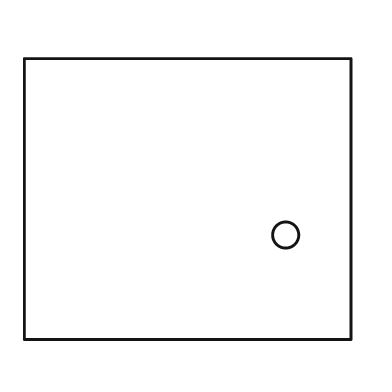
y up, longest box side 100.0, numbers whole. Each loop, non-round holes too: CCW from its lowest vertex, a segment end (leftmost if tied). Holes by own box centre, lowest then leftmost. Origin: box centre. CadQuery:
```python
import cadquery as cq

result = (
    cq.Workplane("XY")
    .moveTo(-50.0, -43.0)
    .lineTo(50.0, -43.0)
    .lineTo(50.0, 43.0)
    .lineTo(-50.0, 43.0)
    .close()
    .moveTo(30.0, -11.0)
    .circle(4.0)
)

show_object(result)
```